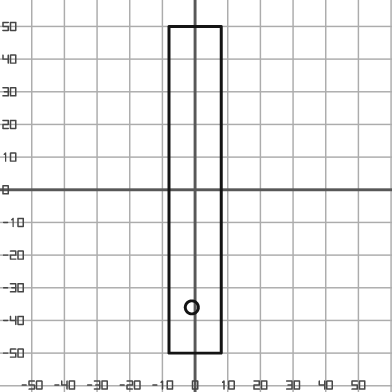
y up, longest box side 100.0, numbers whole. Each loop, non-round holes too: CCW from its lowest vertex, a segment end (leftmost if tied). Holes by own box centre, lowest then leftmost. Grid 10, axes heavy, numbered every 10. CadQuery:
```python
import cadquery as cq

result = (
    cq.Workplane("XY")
    .moveTo(-8.0, -50.0)
    .lineTo(8.0, -50.0)
    .lineTo(8.0, 50.0)
    .lineTo(-8.0, 50.0)
    .close()
    .moveTo(-1.0, -36.0)
    .circle(2.0)
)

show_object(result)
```